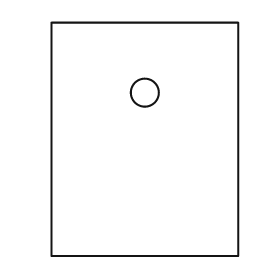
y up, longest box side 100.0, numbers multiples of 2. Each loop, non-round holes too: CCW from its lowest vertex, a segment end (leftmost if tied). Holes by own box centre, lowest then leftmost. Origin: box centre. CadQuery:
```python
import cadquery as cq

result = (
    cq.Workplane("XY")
    .moveTo(-40.0, -50.0)
    .lineTo(40.0, -50.0)
    .lineTo(40.0, 50.0)
    .lineTo(-40.0, 50.0)
    .close()
    .moveTo(0.0, 20.0)
    .circle(6.0)
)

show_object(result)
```